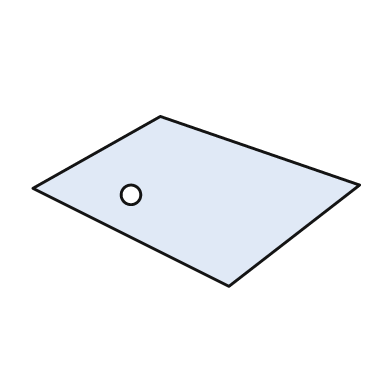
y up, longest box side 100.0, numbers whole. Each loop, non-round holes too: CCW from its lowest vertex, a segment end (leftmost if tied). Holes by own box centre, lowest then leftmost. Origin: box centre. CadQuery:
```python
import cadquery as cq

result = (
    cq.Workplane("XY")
    .moveTo(10.0, -26.0)
    .lineTo(50.0, 5.0)
    .lineTo(-11.0, 26.0)
    .lineTo(-50.0, 4.0)
    .close()
    .moveTo(-20.0, 2.0)
    .circle(3.0)
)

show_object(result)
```